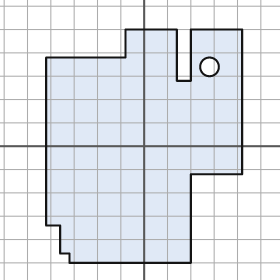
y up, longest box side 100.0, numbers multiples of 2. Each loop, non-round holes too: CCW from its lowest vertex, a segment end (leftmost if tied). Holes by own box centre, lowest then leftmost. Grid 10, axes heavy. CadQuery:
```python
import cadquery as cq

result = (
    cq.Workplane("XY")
    .moveTo(-32.0, -50.0)
    .lineTo(20.0, -50.0)
    .lineTo(20.0, -12.0)
    .lineTo(42.0, -12.0)
    .lineTo(42.0, 50.0)
    .lineTo(20.0, 50.0)
    .lineTo(20.0, 28.0)
    .lineTo(14.0, 28.0)
    .lineTo(14.0, 50.0)
    .lineTo(-8.0, 50.0)
    .lineTo(-8.0, 38.0)
    .lineTo(-42.0, 38.0)
    .lineTo(-42.0, -34.0)
    .lineTo(-36.0, -34.0)
    .lineTo(-36.0, -46.0)
    .lineTo(-32.0, -46.0)
    .close()
    .moveTo(28.0, 34.0)
    .circle(4.0)
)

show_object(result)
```